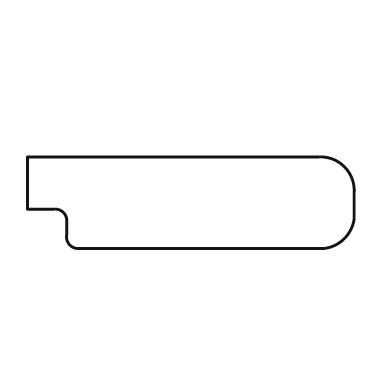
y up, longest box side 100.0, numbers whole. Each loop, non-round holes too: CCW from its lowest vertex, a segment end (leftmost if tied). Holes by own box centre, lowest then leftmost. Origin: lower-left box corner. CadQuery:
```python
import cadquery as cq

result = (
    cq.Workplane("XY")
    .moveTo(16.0, 0.0)
    .lineTo(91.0, 0.0)
    .threePointArc((97.0, 3.0), (100.0, 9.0))
    .lineTo(100.0, 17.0)
    .threePointArc((97.0, 25.0), (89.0, 28.0))
    .lineTo(0.0, 28.0)
    .lineTo(0.0, 12.0)
    .lineTo(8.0, 12.0)
    .threePointArc((11.0, 11.0), (12.0, 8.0))
    .lineTo(12.0, 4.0)
    .threePointArc((13.0, 1.0), (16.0, 0.0))
    .close()
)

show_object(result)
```